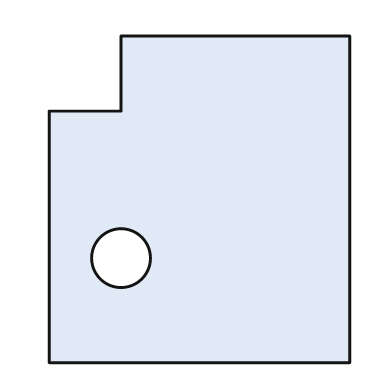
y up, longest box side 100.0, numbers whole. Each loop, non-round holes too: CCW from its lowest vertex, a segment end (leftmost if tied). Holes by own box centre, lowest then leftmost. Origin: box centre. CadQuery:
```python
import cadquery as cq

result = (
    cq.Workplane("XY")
    .moveTo(-46.0, -50.0)
    .lineTo(46.0, -50.0)
    .lineTo(46.0, 50.0)
    .lineTo(-24.0, 50.0)
    .lineTo(-24.0, 27.0)
    .lineTo(-46.0, 27.0)
    .close()
    .moveTo(-24.0, -18.0)
    .circle(9.0)
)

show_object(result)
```